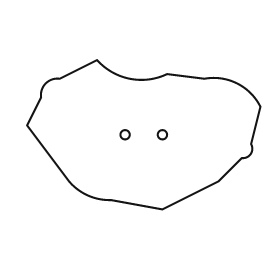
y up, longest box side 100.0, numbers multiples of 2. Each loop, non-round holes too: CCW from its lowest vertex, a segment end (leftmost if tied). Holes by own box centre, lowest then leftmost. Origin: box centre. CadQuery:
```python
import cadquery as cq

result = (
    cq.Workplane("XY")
    .moveTo(8.0, -32.0)
    .lineTo(32.0, -20.0)
    .lineTo(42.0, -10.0)
    .threePointArc((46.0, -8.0), (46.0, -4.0))
    .lineTo(50.0, 12.0)
    .threePointArc((40.0, 22.0), (26.0, 24.0))
    .lineTo(10.0, 26.0)
    .threePointArc((-6.0, 24.0), (-20.0, 32.0))
    .lineTo(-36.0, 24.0)
    .threePointArc((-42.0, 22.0), (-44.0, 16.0))
    .lineTo(-50.0, 4.0)
    .lineTo(-32.0, -20.0)
    .threePointArc((-24.0, -26.0), (-14.0, -28.0))
    .close()
    .moveTo(-8.0, 0.0)
    .circle(2.0)
    .moveTo(8.0, 0.0)
    .circle(2.0)
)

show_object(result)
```